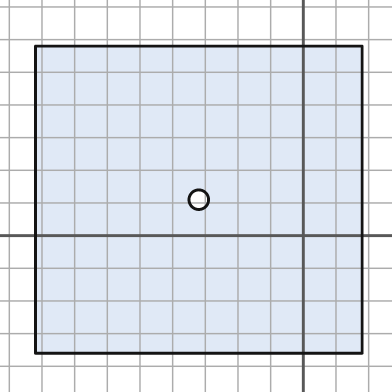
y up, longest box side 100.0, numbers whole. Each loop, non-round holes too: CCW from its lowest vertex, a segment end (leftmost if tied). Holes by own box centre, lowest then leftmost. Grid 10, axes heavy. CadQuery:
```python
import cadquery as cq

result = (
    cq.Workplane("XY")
    .moveTo(-82.0, -36.0)
    .lineTo(18.0, -36.0)
    .lineTo(18.0, 58.0)
    .lineTo(-82.0, 58.0)
    .close()
    .moveTo(-32.0, 11.0)
    .circle(3.0)
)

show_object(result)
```